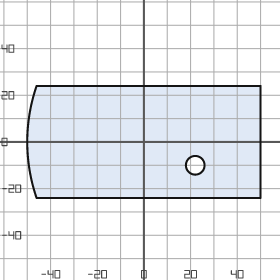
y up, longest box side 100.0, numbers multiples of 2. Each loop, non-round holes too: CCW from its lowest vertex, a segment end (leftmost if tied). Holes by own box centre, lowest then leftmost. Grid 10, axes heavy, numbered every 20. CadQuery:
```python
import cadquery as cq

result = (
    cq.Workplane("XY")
    .moveTo(-46.0, -24.0)
    .lineTo(50.0, -24.0)
    .lineTo(50.0, 24.0)
    .lineTo(-46.0, 24.0)
    .threePointArc((-50.0, 0.0), (-46.0, -24.0))
    .close()
    .moveTo(22.0, -10.0)
    .circle(4.0)
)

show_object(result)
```